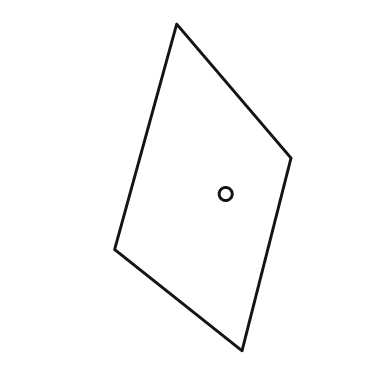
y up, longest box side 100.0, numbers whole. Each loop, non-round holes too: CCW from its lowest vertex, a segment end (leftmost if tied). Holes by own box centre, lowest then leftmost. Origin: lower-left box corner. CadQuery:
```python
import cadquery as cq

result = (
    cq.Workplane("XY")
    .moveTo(39.0, 0.0)
    .lineTo(54.0, 59.0)
    .lineTo(19.0, 100.0)
    .lineTo(0.0, 31.0)
    .close()
    .moveTo(34.0, 48.0)
    .circle(2.0)
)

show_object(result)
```